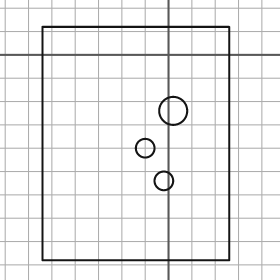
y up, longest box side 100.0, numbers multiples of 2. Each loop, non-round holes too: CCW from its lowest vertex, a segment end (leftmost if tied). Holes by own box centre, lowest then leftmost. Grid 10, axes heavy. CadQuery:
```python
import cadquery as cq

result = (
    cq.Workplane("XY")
    .moveTo(-54.0, -88.0)
    .lineTo(26.0, -88.0)
    .lineTo(26.0, 12.0)
    .lineTo(-54.0, 12.0)
    .close()
    .moveTo(-2.0, -54.0)
    .circle(4.0)
    .moveTo(-10.0, -40.0)
    .circle(4.0)
    .moveTo(2.0, -24.0)
    .circle(6.0)
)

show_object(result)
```